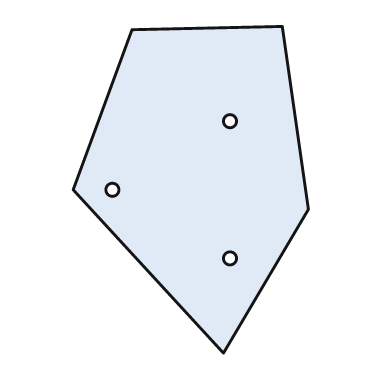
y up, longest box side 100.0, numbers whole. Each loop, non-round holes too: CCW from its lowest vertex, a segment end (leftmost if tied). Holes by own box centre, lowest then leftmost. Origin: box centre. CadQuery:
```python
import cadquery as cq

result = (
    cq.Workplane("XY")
    .moveTo(10.0, -50.0)
    .lineTo(36.0, -6.0)
    .lineTo(28.0, 50.0)
    .lineTo(-18.0, 49.0)
    .lineTo(-36.0, 0.0)
    .close()
    .moveTo(12.0, -21.0)
    .circle(2.0)
    .moveTo(-24.0, 0.0)
    .circle(2.0)
    .moveTo(12.0, 21.0)
    .circle(2.0)
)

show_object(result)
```